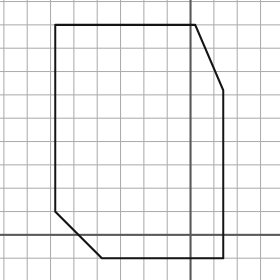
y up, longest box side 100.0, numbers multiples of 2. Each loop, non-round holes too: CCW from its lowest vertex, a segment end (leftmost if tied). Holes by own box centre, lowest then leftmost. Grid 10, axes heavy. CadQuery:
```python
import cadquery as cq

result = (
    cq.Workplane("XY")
    .moveTo(-38.0, -10.0)
    .lineTo(14.0, -10.0)
    .lineTo(14.0, 62.0)
    .lineTo(2.0, 90.0)
    .lineTo(-58.0, 90.0)
    .lineTo(-58.0, 10.0)
    .close()
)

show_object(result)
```